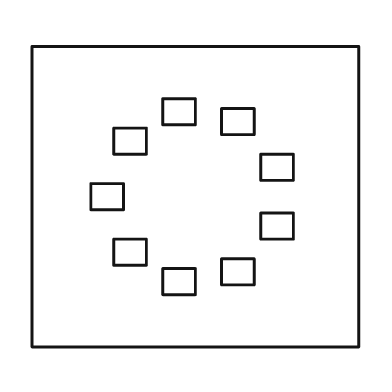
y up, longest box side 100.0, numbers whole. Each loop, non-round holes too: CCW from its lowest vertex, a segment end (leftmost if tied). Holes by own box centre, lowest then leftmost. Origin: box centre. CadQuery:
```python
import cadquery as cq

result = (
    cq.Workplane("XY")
    .moveTo(-50.0, -46.0)
    .lineTo(50.0, -46.0)
    .lineTo(50.0, 46.0)
    .lineTo(-50.0, 46.0)
    .close()
    .moveTo(-10.0, -30.0)
    .lineTo(0.0, -30.0)
    .lineTo(0.0, -22.0)
    .lineTo(-10.0, -22.0)
    .close()
    .moveTo(8.0, -27.0)
    .lineTo(18.0, -27.0)
    .lineTo(18.0, -19.0)
    .lineTo(8.0, -19.0)
    .close()
    .moveTo(-25.0, -21.0)
    .lineTo(-15.0, -21.0)
    .lineTo(-15.0, -13.0)
    .lineTo(-25.0, -13.0)
    .close()
    .moveTo(20.0, -13.0)
    .lineTo(30.0, -13.0)
    .lineTo(30.0, -5.0)
    .lineTo(20.0, -5.0)
    .close()
    .moveTo(-32.0, -4.0)
    .lineTo(-22.0, -4.0)
    .lineTo(-22.0, 4.0)
    .lineTo(-32.0, 4.0)
    .close()
    .moveTo(20.0, 5.0)
    .lineTo(30.0, 5.0)
    .lineTo(30.0, 13.0)
    .lineTo(20.0, 13.0)
    .close()
    .moveTo(-25.0, 13.0)
    .lineTo(-15.0, 13.0)
    .lineTo(-15.0, 21.0)
    .lineTo(-25.0, 21.0)
    .close()
    .moveTo(8.0, 19.0)
    .lineTo(18.0, 19.0)
    .lineTo(18.0, 27.0)
    .lineTo(8.0, 27.0)
    .close()
    .moveTo(-10.0, 22.0)
    .lineTo(0.0, 22.0)
    .lineTo(0.0, 30.0)
    .lineTo(-10.0, 30.0)
    .close()
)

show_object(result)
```